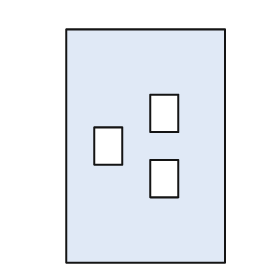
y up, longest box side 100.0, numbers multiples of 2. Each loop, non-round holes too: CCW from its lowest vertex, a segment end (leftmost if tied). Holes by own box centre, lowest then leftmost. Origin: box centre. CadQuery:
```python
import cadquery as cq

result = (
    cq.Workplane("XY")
    .moveTo(-34.0, -50.0)
    .lineTo(34.0, -50.0)
    .lineTo(34.0, 50.0)
    .lineTo(-34.0, 50.0)
    .close()
    .moveTo(2.0, -22.0)
    .lineTo(14.0, -22.0)
    .lineTo(14.0, -6.0)
    .lineTo(2.0, -6.0)
    .close()
    .moveTo(-22.0, -8.0)
    .lineTo(-10.0, -8.0)
    .lineTo(-10.0, 8.0)
    .lineTo(-22.0, 8.0)
    .close()
    .moveTo(2.0, 6.0)
    .lineTo(14.0, 6.0)
    .lineTo(14.0, 22.0)
    .lineTo(2.0, 22.0)
    .close()
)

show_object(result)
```